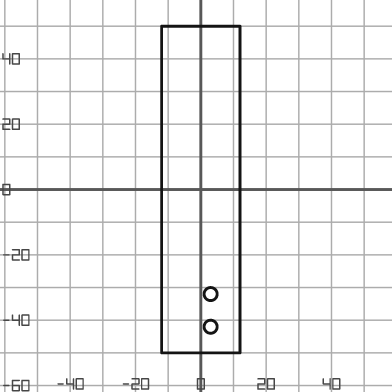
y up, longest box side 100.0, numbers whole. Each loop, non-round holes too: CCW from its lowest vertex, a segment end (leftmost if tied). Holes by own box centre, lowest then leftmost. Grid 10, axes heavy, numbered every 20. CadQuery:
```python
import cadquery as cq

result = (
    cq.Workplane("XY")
    .moveTo(-12.0, -50.0)
    .lineTo(12.0, -50.0)
    .lineTo(12.0, 50.0)
    .lineTo(-12.0, 50.0)
    .close()
    .moveTo(3.0, -42.0)
    .circle(2.0)
    .moveTo(3.0, -32.0)
    .circle(2.0)
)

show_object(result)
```